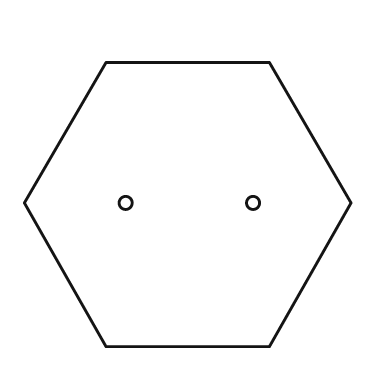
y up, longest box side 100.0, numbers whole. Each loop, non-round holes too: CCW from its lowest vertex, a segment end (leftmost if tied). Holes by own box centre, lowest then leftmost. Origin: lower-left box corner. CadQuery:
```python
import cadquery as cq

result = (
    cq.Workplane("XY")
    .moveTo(25.0, 0.0)
    .lineTo(75.0, 0.0)
    .lineTo(100.0, 44.0)
    .lineTo(75.0, 87.0)
    .lineTo(25.0, 87.0)
    .lineTo(0.0, 44.0)
    .close()
    .moveTo(31.0, 44.0)
    .circle(2.0)
    .moveTo(70.0, 44.0)
    .circle(2.0)
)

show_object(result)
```